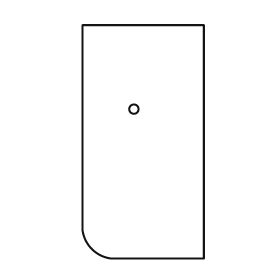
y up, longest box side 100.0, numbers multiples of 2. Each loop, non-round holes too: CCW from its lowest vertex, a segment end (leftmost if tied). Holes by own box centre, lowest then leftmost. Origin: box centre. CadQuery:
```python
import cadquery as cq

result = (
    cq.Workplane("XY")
    .moveTo(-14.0, -50.0)
    .lineTo(26.0, -50.0)
    .lineTo(26.0, 50.0)
    .lineTo(-26.0, 50.0)
    .lineTo(-26.0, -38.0)
    .threePointArc((-22.0, -46.0), (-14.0, -50.0))
    .close()
    .moveTo(-4.0, 14.0)
    .circle(2.0)
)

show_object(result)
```